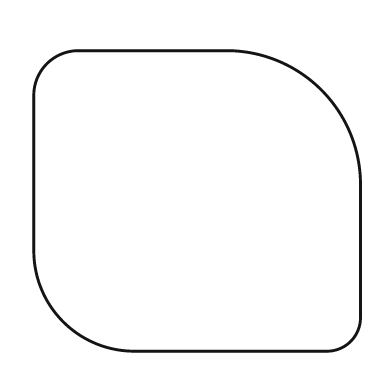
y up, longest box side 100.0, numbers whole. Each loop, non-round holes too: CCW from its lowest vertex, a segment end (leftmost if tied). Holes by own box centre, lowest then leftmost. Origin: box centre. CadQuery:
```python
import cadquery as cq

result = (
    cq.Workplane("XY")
    .moveTo(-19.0, -46.0)
    .lineTo(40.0, -46.0)
    .threePointArc((47.0, -43.0), (50.0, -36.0))
    .lineTo(50.0, 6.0)
    .threePointArc((38.0, 34.0), (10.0, 46.0))
    .lineTo(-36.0, 46.0)
    .threePointArc((-46.0, 42.0), (-50.0, 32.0))
    .lineTo(-50.0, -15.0)
    .threePointArc((-41.0, -37.0), (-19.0, -46.0))
    .close()
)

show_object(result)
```